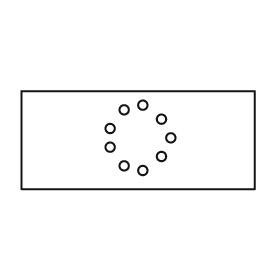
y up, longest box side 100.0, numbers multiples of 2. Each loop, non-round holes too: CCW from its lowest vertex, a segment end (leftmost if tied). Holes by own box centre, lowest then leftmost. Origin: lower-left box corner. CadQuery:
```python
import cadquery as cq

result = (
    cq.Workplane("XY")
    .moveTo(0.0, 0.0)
    .lineTo(100.0, 0.0)
    .lineTo(100.0, 42.0)
    .lineTo(0.0, 42.0)
    .close()
    .moveTo(52.0, 8.0)
    .circle(2.0)
    .moveTo(44.0, 10.0)
    .circle(2.0)
    .moveTo(60.0, 14.0)
    .circle(2.0)
    .moveTo(38.0, 18.0)
    .circle(2.0)
    .moveTo(64.0, 22.0)
    .circle(2.0)
    .moveTo(38.0, 26.0)
    .circle(2.0)
    .moveTo(60.0, 30.0)
    .circle(2.0)
    .moveTo(44.0, 34.0)
    .circle(2.0)
    .moveTo(52.0, 36.0)
    .circle(2.0)
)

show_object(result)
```